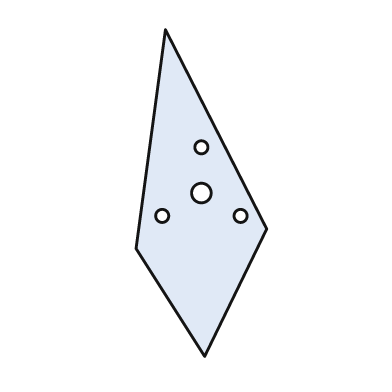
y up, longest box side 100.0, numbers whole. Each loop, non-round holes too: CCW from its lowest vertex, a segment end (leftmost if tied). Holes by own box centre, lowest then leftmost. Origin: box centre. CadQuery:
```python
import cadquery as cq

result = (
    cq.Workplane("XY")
    .moveTo(1.0, -50.0)
    .lineTo(20.0, -11.0)
    .lineTo(-11.0, 50.0)
    .lineTo(-20.0, -17.0)
    .close()
    .moveTo(-12.0, -7.0)
    .circle(2.0)
    .moveTo(12.0, -7.0)
    .circle(2.0)
    .moveTo(0.0, 0.0)
    .circle(3.0)
    .moveTo(0.0, 14.0)
    .circle(2.0)
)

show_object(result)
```